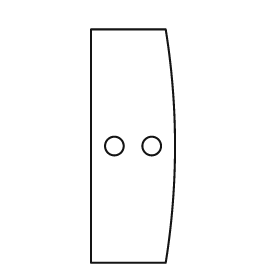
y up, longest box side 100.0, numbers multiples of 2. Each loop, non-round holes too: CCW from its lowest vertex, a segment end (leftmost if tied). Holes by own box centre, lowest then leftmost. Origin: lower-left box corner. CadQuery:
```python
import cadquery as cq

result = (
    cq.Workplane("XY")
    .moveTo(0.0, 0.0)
    .lineTo(32.0, 0.0)
    .threePointArc((36.0, 50.0), (32.0, 100.0))
    .lineTo(0.0, 100.0)
    .close()
    .moveTo(10.0, 50.0)
    .circle(4.0)
    .moveTo(26.0, 50.0)
    .circle(4.0)
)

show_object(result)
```